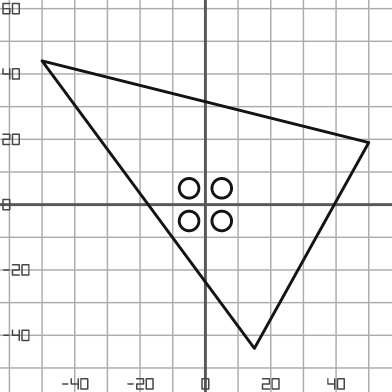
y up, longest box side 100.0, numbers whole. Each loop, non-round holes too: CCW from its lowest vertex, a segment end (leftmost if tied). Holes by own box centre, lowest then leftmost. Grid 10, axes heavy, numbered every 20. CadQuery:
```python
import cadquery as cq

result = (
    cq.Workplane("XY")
    .moveTo(15.0, -44.0)
    .lineTo(50.0, 19.0)
    .lineTo(-50.0, 44.0)
    .close()
    .moveTo(-5.0, -5.0)
    .circle(3.0)
    .moveTo(5.0, -5.0)
    .circle(3.0)
    .moveTo(-5.0, 5.0)
    .circle(3.0)
    .moveTo(5.0, 5.0)
    .circle(3.0)
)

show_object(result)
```